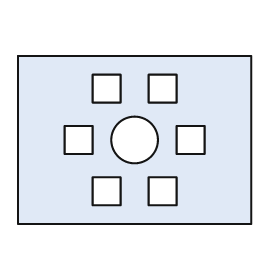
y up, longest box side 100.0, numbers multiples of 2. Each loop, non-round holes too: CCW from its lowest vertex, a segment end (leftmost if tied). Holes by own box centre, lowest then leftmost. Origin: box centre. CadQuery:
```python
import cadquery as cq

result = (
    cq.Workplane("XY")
    .moveTo(-50.0, -36.0)
    .lineTo(50.0, -36.0)
    .lineTo(50.0, 36.0)
    .lineTo(-50.0, 36.0)
    .close()
    .moveTo(-18.0, -28.0)
    .lineTo(-6.0, -28.0)
    .lineTo(-6.0, -16.0)
    .lineTo(-18.0, -16.0)
    .close()
    .moveTo(6.0, -28.0)
    .lineTo(18.0, -28.0)
    .lineTo(18.0, -16.0)
    .lineTo(6.0, -16.0)
    .close()
    .moveTo(-30.0, -6.0)
    .lineTo(-18.0, -6.0)
    .lineTo(-18.0, 6.0)
    .lineTo(-30.0, 6.0)
    .close()
    .moveTo(0.0, 0.0)
    .circle(10.0)
    .moveTo(18.0, -6.0)
    .lineTo(30.0, -6.0)
    .lineTo(30.0, 6.0)
    .lineTo(18.0, 6.0)
    .close()
    .moveTo(-18.0, 16.0)
    .lineTo(-6.0, 16.0)
    .lineTo(-6.0, 28.0)
    .lineTo(-18.0, 28.0)
    .close()
    .moveTo(6.0, 16.0)
    .lineTo(18.0, 16.0)
    .lineTo(18.0, 28.0)
    .lineTo(6.0, 28.0)
    .close()
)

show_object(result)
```